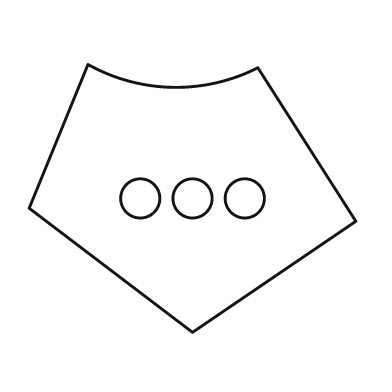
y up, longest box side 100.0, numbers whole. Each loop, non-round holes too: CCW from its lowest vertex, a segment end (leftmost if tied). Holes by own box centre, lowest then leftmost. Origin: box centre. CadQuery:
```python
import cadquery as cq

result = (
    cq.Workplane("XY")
    .moveTo(0.0, -41.0)
    .lineTo(50.0, -7.0)
    .lineTo(20.0, 40.0)
    .threePointArc((-6.0, 34.0), (-32.0, 41.0))
    .lineTo(-50.0, -3.0)
    .close()
    .moveTo(-16.0, 0.0)
    .circle(6.0)
    .moveTo(0.0, 0.0)
    .circle(6.0)
    .moveTo(16.0, 0.0)
    .circle(6.0)
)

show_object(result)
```